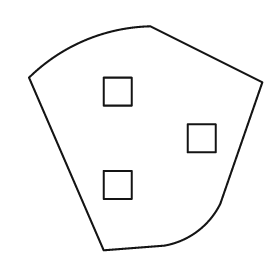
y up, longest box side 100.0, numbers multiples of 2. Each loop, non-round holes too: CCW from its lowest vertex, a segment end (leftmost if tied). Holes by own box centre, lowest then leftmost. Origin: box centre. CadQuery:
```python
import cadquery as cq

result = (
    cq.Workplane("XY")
    .moveTo(-18.0, -48.0)
    .lineTo(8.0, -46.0)
    .threePointArc((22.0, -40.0), (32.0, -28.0))
    .lineTo(50.0, 24.0)
    .lineTo(2.0, 48.0)
    .threePointArc((-26.0, 42.0), (-50.0, 26.0))
    .close()
    .moveTo(-18.0, -26.0)
    .lineTo(-6.0, -26.0)
    .lineTo(-6.0, -14.0)
    .lineTo(-18.0, -14.0)
    .close()
    .moveTo(18.0, -6.0)
    .lineTo(30.0, -6.0)
    .lineTo(30.0, 6.0)
    .lineTo(18.0, 6.0)
    .close()
    .moveTo(-18.0, 14.0)
    .lineTo(-6.0, 14.0)
    .lineTo(-6.0, 26.0)
    .lineTo(-18.0, 26.0)
    .close()
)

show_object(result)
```